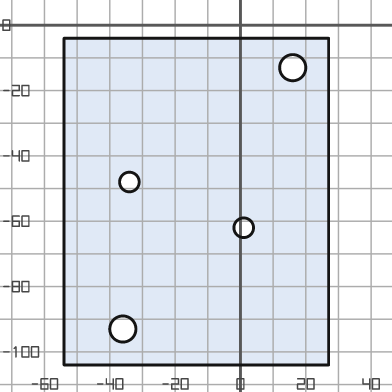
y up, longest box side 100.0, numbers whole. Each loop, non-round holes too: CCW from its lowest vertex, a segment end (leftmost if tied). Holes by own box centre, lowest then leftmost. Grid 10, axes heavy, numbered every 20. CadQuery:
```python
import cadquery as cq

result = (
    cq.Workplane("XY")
    .moveTo(-54.0, -104.0)
    .lineTo(27.0, -104.0)
    .lineTo(27.0, -4.0)
    .lineTo(-54.0, -4.0)
    .close()
    .moveTo(-36.0, -93.0)
    .circle(4.0)
    .moveTo(1.0, -62.0)
    .circle(3.0)
    .moveTo(-34.0, -48.0)
    .circle(3.0)
    .moveTo(16.0, -13.0)
    .circle(4.0)
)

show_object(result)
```